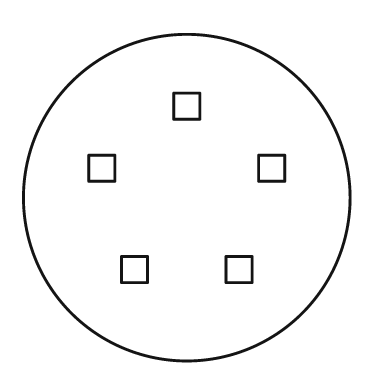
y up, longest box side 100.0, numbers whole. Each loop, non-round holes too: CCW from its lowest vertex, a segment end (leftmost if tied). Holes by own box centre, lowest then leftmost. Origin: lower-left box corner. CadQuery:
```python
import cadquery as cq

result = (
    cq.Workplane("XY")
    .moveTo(50.0, 50.0)
    .circle(50.0)
    .moveTo(30.0, 24.0)
    .lineTo(38.0, 24.0)
    .lineTo(38.0, 32.0)
    .lineTo(30.0, 32.0)
    .close()
    .moveTo(62.0, 24.0)
    .lineTo(70.0, 24.0)
    .lineTo(70.0, 32.0)
    .lineTo(62.0, 32.0)
    .close()
    .moveTo(20.0, 55.0)
    .lineTo(28.0, 55.0)
    .lineTo(28.0, 63.0)
    .lineTo(20.0, 63.0)
    .close()
    .moveTo(72.0, 55.0)
    .lineTo(80.0, 55.0)
    .lineTo(80.0, 63.0)
    .lineTo(72.0, 63.0)
    .close()
    .moveTo(46.0, 74.0)
    .lineTo(54.0, 74.0)
    .lineTo(54.0, 82.0)
    .lineTo(46.0, 82.0)
    .close()
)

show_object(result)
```